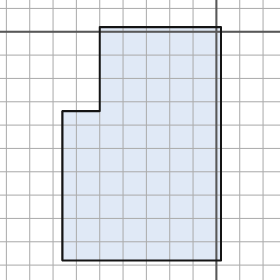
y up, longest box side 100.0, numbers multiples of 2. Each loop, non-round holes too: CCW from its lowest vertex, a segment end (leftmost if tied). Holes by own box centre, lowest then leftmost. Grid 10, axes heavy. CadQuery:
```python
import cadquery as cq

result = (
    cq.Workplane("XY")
    .moveTo(-66.0, -98.0)
    .lineTo(2.0, -98.0)
    .lineTo(2.0, 2.0)
    .lineTo(-50.0, 2.0)
    .lineTo(-50.0, -34.0)
    .lineTo(-66.0, -34.0)
    .close()
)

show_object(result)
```